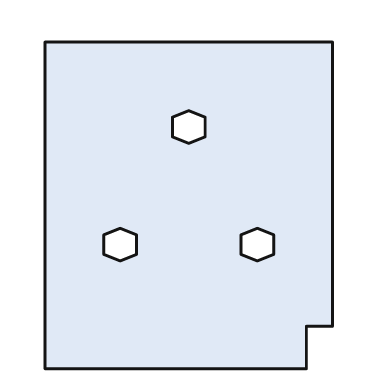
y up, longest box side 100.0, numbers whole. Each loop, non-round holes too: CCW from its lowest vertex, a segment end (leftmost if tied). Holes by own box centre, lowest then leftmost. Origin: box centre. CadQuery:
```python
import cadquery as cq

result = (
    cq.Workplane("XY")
    .moveTo(-44.0, -50.0)
    .lineTo(36.0, -50.0)
    .lineTo(36.0, -37.0)
    .lineTo(44.0, -37.0)
    .lineTo(44.0, 50.0)
    .lineTo(-44.0, 50.0)
    .close()
    .moveTo(-21.0, -17.0)
    .lineTo(-16.0, -15.0)
    .lineTo(-16.0, -9.0)
    .lineTo(-21.0, -7.0)
    .lineTo(-26.0, -9.0)
    .lineTo(-26.0, -15.0)
    .close()
    .moveTo(21.0, -17.0)
    .lineTo(26.0, -15.0)
    .lineTo(26.0, -9.0)
    .lineTo(21.0, -7.0)
    .lineTo(16.0, -9.0)
    .lineTo(16.0, -15.0)
    .close()
    .moveTo(0.0, 19.0)
    .lineTo(5.0, 21.0)
    .lineTo(5.0, 27.0)
    .lineTo(0.0, 29.0)
    .lineTo(-5.0, 27.0)
    .lineTo(-5.0, 21.0)
    .close()
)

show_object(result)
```